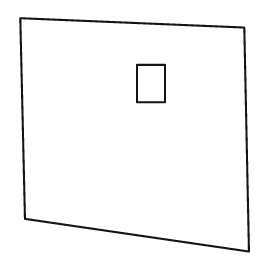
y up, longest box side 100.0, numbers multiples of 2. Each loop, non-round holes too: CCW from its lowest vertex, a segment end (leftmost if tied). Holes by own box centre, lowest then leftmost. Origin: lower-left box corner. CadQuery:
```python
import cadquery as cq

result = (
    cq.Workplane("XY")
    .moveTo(98.0, 0.0)
    .lineTo(96.0, 96.0)
    .lineTo(0.0, 100.0)
    .lineTo(2.0, 14.0)
    .close()
    .moveTo(50.0, 64.0)
    .lineTo(62.0, 64.0)
    .lineTo(62.0, 80.0)
    .lineTo(50.0, 80.0)
    .close()
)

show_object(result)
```